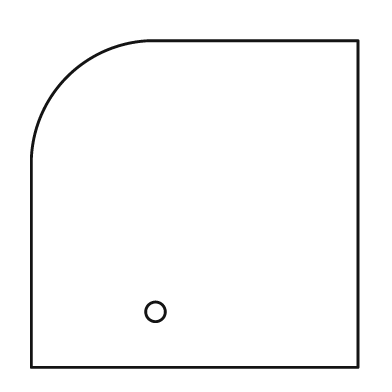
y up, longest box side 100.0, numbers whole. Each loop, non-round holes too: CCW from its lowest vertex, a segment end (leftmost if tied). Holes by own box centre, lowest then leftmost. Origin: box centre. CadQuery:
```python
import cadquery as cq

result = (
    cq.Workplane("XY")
    .moveTo(-50.0, -50.0)
    .lineTo(50.0, -50.0)
    .lineTo(50.0, 50.0)
    .lineTo(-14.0, 50.0)
    .threePointArc((-39.0, 39.0), (-50.0, 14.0))
    .close()
    .moveTo(-12.0, -33.0)
    .circle(3.0)
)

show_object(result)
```